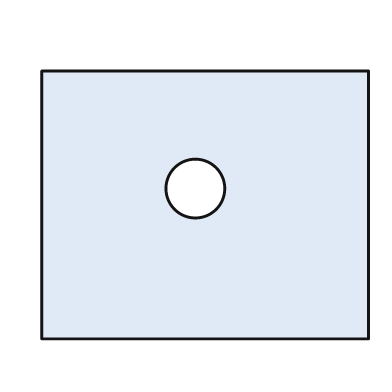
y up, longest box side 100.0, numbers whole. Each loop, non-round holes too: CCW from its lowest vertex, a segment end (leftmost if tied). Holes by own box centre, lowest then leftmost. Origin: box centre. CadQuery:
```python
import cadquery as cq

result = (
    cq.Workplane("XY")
    .moveTo(-50.0, -41.0)
    .lineTo(50.0, -41.0)
    .lineTo(50.0, 41.0)
    .lineTo(-50.0, 41.0)
    .close()
    .moveTo(-3.0, 5.0)
    .circle(9.0)
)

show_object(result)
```